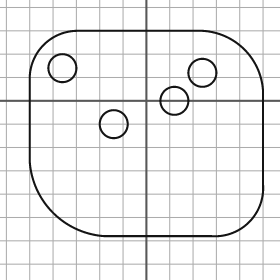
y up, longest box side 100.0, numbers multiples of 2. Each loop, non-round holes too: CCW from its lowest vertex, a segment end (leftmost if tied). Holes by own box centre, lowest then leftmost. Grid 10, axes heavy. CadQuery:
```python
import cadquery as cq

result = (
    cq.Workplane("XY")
    .moveTo(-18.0, -58.0)
    .lineTo(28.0, -58.0)
    .threePointArc((44.0, -52.0), (50.0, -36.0))
    .lineTo(50.0, 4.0)
    .threePointArc((42.0, 22.0), (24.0, 30.0))
    .lineTo(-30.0, 30.0)
    .threePointArc((-44.0, 24.0), (-50.0, 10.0))
    .lineTo(-50.0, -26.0)
    .threePointArc((-40.0, -48.0), (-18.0, -58.0))
    .close()
    .moveTo(-14.0, -10.0)
    .circle(6.0)
    .moveTo(12.0, 0.0)
    .circle(6.0)
    .moveTo(24.0, 12.0)
    .circle(6.0)
    .moveTo(-36.0, 14.0)
    .circle(6.0)
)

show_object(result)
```